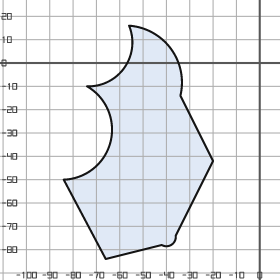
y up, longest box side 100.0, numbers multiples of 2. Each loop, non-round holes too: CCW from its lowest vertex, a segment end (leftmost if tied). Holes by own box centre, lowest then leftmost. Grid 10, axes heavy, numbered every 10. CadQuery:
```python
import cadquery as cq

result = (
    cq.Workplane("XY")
    .moveTo(-66.0, -84.0)
    .lineTo(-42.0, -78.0)
    .threePointArc((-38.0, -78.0), (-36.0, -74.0))
    .lineTo(-20.0, -42.0)
    .lineTo(-34.0, -14.0)
    .threePointArc((-38.0, 6.0), (-56.0, 16.0))
    .threePointArc((-58.0, -2.0), (-74.0, -10.0))
    .threePointArc((-64.0, -34.0), (-84.0, -50.0))
    .close()
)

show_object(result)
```